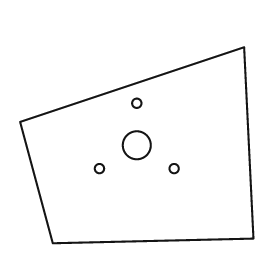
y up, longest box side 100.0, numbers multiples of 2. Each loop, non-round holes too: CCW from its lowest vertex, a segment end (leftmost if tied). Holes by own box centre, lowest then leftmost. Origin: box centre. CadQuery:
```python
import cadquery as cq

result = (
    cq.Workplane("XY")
    .moveTo(-36.0, -42.0)
    .lineTo(50.0, -40.0)
    .lineTo(46.0, 42.0)
    .lineTo(-50.0, 10.0)
    .close()
    .moveTo(-16.0, -10.0)
    .circle(2.0)
    .moveTo(16.0, -10.0)
    .circle(2.0)
    .moveTo(0.0, 0.0)
    .circle(6.0)
    .moveTo(0.0, 18.0)
    .circle(2.0)
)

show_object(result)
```